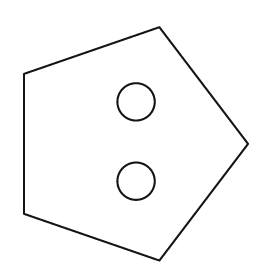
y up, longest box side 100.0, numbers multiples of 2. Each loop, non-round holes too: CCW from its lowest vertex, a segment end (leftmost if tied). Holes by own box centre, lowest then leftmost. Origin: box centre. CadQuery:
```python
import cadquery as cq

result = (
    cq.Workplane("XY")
    .moveTo(10.0, -50.0)
    .lineTo(48.0, 0.0)
    .lineTo(10.0, 50.0)
    .lineTo(-48.0, 30.0)
    .lineTo(-48.0, -30.0)
    .close()
    .moveTo(0.0, -16.0)
    .circle(8.0)
    .moveTo(0.0, 18.0)
    .circle(8.0)
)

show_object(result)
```